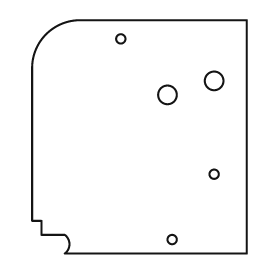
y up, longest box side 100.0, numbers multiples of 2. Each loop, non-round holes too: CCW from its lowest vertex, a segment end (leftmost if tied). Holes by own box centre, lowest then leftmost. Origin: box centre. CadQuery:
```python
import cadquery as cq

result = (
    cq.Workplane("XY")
    .moveTo(-32.0, -50.0)
    .lineTo(46.0, -50.0)
    .lineTo(46.0, 50.0)
    .lineTo(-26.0, 50.0)
    .threePointArc((-40.0, 44.0), (-46.0, 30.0))
    .lineTo(-46.0, -36.0)
    .lineTo(-42.0, -36.0)
    .lineTo(-42.0, -42.0)
    .lineTo(-32.0, -42.0)
    .threePointArc((-30.0, -46.0), (-32.0, -50.0))
    .close()
    .moveTo(14.0, -44.0)
    .circle(2.0)
    .moveTo(32.0, -16.0)
    .circle(2.0)
    .moveTo(12.0, 18.0)
    .circle(4.0)
    .moveTo(32.0, 24.0)
    .circle(4.0)
    .moveTo(-8.0, 42.0)
    .circle(2.0)
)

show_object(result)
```